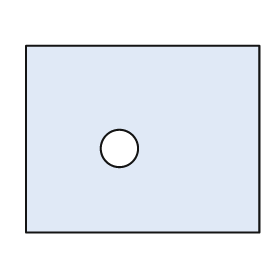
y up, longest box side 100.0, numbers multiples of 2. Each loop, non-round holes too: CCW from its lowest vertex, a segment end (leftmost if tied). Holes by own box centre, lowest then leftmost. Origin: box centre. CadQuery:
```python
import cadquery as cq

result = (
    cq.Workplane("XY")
    .moveTo(-50.0, -40.0)
    .lineTo(50.0, -40.0)
    .lineTo(50.0, 40.0)
    .lineTo(-50.0, 40.0)
    .close()
    .moveTo(-10.0, -4.0)
    .circle(8.0)
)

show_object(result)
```